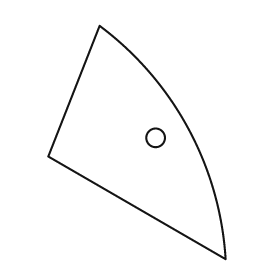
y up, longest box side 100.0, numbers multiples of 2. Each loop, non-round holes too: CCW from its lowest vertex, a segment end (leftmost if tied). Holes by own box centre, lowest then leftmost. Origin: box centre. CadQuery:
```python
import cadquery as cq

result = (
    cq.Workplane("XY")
    .moveTo(38.0, -50.0)
    .threePointArc((22.0, 6.0), (-16.0, 50.0))
    .lineTo(-38.0, -6.0)
    .close()
    .moveTo(8.0, 2.0)
    .circle(4.0)
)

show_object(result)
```